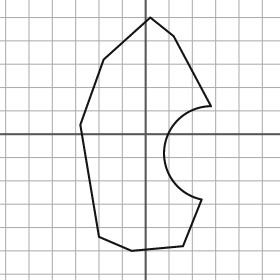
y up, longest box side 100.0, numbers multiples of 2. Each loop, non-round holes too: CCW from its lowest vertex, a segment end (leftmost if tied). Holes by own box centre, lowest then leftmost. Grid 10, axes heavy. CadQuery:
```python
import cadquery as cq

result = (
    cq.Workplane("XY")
    .moveTo(-6.0, -50.0)
    .lineTo(16.0, -48.0)
    .lineTo(24.0, -28.0)
    .threePointArc((8.0, -6.0), (28.0, 12.0))
    .lineTo(12.0, 42.0)
    .lineTo(2.0, 50.0)
    .lineTo(-18.0, 32.0)
    .lineTo(-28.0, 4.0)
    .lineTo(-20.0, -44.0)
    .close()
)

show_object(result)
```